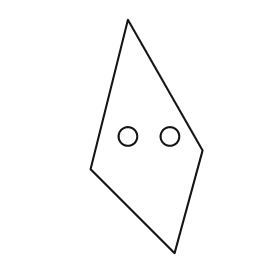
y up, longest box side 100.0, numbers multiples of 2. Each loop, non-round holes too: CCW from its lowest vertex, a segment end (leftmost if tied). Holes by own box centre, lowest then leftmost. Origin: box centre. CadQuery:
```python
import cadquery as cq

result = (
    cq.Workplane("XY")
    .moveTo(12.0, -50.0)
    .lineTo(24.0, -6.0)
    .lineTo(-8.0, 50.0)
    .lineTo(-24.0, -14.0)
    .close()
    .moveTo(-8.0, 0.0)
    .circle(4.0)
    .moveTo(10.0, 0.0)
    .circle(4.0)
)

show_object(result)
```